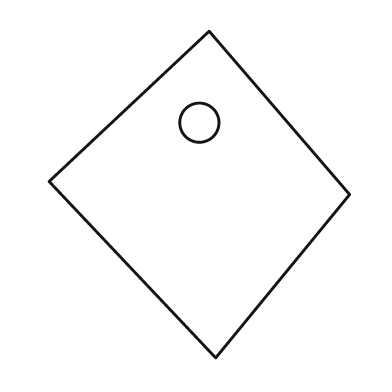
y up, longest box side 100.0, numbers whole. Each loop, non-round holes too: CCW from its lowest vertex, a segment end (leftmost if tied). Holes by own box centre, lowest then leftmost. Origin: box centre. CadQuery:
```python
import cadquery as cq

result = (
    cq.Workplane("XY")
    .moveTo(5.0, -50.0)
    .lineTo(46.0, 0.0)
    .lineTo(3.0, 50.0)
    .lineTo(-46.0, 4.0)
    .close()
    .moveTo(0.0, 22.0)
    .circle(6.0)
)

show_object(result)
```